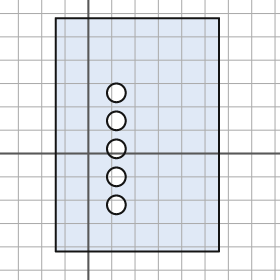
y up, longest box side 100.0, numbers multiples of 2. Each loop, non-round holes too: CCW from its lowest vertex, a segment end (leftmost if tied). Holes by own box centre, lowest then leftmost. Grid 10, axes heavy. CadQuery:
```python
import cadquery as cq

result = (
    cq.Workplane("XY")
    .moveTo(-14.0, -42.0)
    .lineTo(56.0, -42.0)
    .lineTo(56.0, 58.0)
    .lineTo(-14.0, 58.0)
    .close()
    .moveTo(12.0, -22.0)
    .circle(4.0)
    .moveTo(12.0, -10.0)
    .circle(4.0)
    .moveTo(12.0, 2.0)
    .circle(4.0)
    .moveTo(12.0, 14.0)
    .circle(4.0)
    .moveTo(12.0, 26.0)
    .circle(4.0)
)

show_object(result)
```